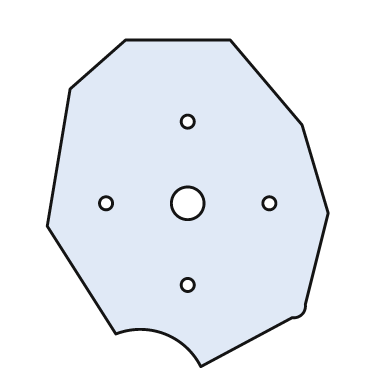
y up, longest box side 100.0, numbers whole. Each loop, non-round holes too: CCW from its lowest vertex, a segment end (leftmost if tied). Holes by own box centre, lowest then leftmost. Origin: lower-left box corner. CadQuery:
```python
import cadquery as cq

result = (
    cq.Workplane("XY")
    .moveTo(47.0, 0.0)
    .lineTo(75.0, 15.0)
    .threePointArc((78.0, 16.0), (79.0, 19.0))
    .lineTo(86.0, 47.0)
    .lineTo(78.0, 74.0)
    .lineTo(56.0, 100.0)
    .lineTo(24.0, 100.0)
    .lineTo(7.0, 85.0)
    .lineTo(0.0, 43.0)
    .lineTo(21.0, 10.0)
    .threePointArc((36.0, 10.0), (47.0, 0.0))
    .close()
    .moveTo(43.0, 25.0)
    .circle(2.0)
    .moveTo(18.0, 50.0)
    .circle(2.0)
    .moveTo(43.0, 50.0)
    .circle(5.0)
    .moveTo(68.0, 50.0)
    .circle(2.0)
    .moveTo(43.0, 75.0)
    .circle(2.0)
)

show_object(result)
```